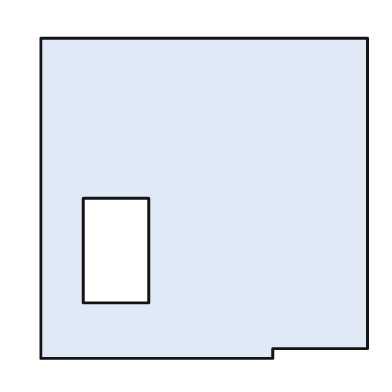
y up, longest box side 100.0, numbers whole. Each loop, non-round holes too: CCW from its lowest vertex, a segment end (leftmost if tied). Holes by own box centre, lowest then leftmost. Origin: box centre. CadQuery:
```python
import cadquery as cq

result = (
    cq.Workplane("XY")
    .moveTo(-50.0, -49.0)
    .lineTo(21.0, -49.0)
    .lineTo(21.0, -46.0)
    .lineTo(50.0, -46.0)
    .lineTo(50.0, 49.0)
    .lineTo(-50.0, 49.0)
    .close()
    .moveTo(-37.0, -32.0)
    .lineTo(-17.0, -32.0)
    .lineTo(-17.0, 0.0)
    .lineTo(-37.0, 0.0)
    .close()
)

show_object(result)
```